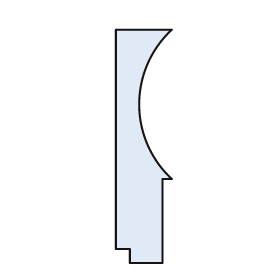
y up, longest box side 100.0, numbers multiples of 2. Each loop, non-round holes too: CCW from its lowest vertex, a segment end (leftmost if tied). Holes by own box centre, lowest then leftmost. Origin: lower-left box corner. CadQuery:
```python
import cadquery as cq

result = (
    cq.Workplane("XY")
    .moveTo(6.0, 0.0)
    .lineTo(20.0, 0.0)
    .lineTo(20.0, 36.0)
    .lineTo(24.0, 36.0)
    .threePointArc((10.0, 68.0), (24.0, 100.0))
    .lineTo(0.0, 100.0)
    .lineTo(0.0, 6.0)
    .lineTo(6.0, 6.0)
    .close()
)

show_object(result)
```